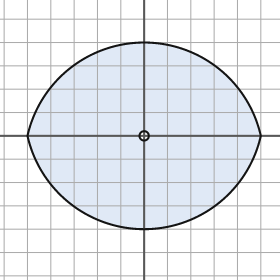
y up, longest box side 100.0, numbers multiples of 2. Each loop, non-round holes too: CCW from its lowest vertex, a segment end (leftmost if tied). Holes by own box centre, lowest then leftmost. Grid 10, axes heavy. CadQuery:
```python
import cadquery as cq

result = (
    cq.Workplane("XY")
    .moveTo(-50.0, 0.0)
    .threePointArc((0.0, -40.0), (50.0, 0.0))
    .threePointArc((0.0, 40.0), (-50.0, 0.0))
    .close()
    .moveTo(0.0, 0.0)
    .circle(2.0)
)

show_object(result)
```